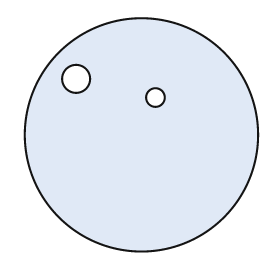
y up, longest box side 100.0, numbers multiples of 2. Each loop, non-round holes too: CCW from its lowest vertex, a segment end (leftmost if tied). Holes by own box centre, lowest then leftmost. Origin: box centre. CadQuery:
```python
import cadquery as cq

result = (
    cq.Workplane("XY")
    .moveTo(0.0, 0.0)
    .circle(50.0)
    .moveTo(6.0, 16.0)
    .circle(4.0)
    .moveTo(-28.0, 24.0)
    .circle(6.0)
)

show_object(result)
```